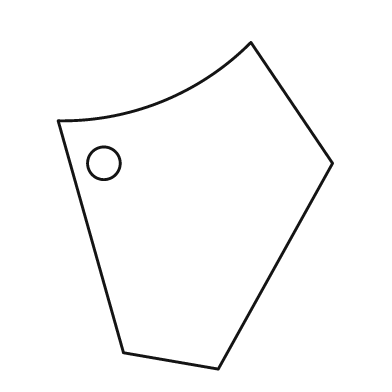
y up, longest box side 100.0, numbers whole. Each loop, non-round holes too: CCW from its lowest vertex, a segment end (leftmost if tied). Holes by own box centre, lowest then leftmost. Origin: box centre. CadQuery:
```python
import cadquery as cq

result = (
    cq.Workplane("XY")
    .moveTo(7.0, -50.0)
    .lineTo(42.0, 13.0)
    .lineTo(17.0, 50.0)
    .threePointArc((-10.0, 32.0), (-42.0, 26.0))
    .lineTo(-22.0, -45.0)
    .close()
    .moveTo(-28.0, 13.0)
    .circle(5.0)
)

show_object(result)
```